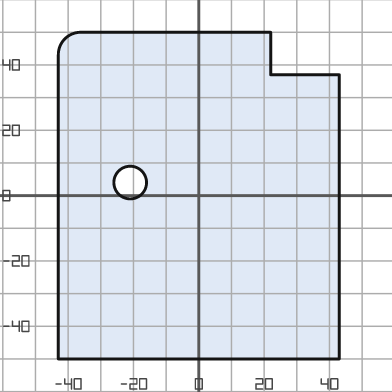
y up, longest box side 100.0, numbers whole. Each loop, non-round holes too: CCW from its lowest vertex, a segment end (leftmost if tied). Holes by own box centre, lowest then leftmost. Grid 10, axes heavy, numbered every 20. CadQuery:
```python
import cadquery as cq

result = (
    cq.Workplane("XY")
    .moveTo(-43.0, -50.0)
    .lineTo(43.0, -50.0)
    .lineTo(43.0, 37.0)
    .lineTo(22.0, 37.0)
    .lineTo(22.0, 50.0)
    .lineTo(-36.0, 50.0)
    .threePointArc((-41.0, 48.0), (-43.0, 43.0))
    .close()
    .moveTo(-21.0, 4.0)
    .circle(5.0)
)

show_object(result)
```